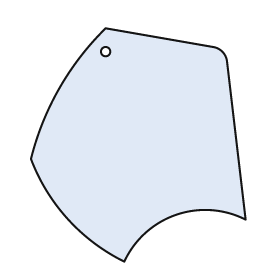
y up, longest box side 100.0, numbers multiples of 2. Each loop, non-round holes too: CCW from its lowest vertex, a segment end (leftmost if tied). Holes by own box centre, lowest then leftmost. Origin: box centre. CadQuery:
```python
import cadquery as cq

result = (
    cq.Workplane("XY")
    .moveTo(-6.0, -50.0)
    .threePointArc((16.0, -30.0), (46.0, -32.0))
    .lineTo(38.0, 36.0)
    .threePointArc((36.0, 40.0), (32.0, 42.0))
    .lineTo(-14.0, 50.0)
    .threePointArc((-34.0, 24.0), (-46.0, -6.0))
    .threePointArc((-30.0, -32.0), (-6.0, -50.0))
    .close()
    .moveTo(-14.0, 40.0)
    .circle(2.0)
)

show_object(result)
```